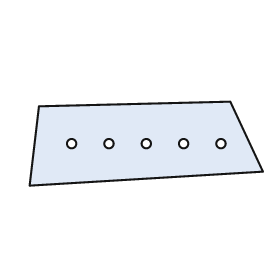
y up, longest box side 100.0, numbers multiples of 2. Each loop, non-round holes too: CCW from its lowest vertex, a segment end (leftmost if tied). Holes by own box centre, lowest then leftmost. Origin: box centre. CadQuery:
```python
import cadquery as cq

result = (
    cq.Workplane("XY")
    .moveTo(-50.0, -18.0)
    .lineTo(50.0, -12.0)
    .lineTo(36.0, 18.0)
    .lineTo(-46.0, 16.0)
    .close()
    .moveTo(-32.0, 0.0)
    .circle(2.0)
    .moveTo(-16.0, 0.0)
    .circle(2.0)
    .moveTo(0.0, 0.0)
    .circle(2.0)
    .moveTo(16.0, 0.0)
    .circle(2.0)
    .moveTo(32.0, 0.0)
    .circle(2.0)
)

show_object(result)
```